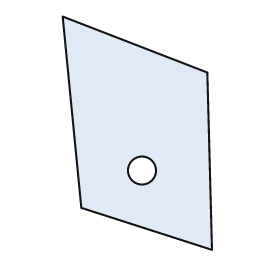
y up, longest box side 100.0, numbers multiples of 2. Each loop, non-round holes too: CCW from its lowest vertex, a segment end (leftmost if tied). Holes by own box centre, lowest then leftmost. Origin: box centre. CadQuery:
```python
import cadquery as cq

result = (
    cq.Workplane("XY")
    .moveTo(32.0, -50.0)
    .lineTo(30.0, 26.0)
    .lineTo(-32.0, 50.0)
    .lineTo(-24.0, -32.0)
    .close()
    .moveTo(2.0, -16.0)
    .circle(6.0)
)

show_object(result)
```